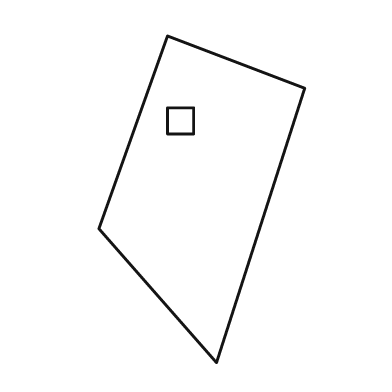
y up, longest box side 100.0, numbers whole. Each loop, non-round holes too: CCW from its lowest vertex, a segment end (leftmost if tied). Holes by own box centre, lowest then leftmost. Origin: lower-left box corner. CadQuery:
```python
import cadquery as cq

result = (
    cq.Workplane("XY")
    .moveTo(36.0, 0.0)
    .lineTo(63.0, 84.0)
    .lineTo(21.0, 100.0)
    .lineTo(0.0, 41.0)
    .close()
    .moveTo(21.0, 70.0)
    .lineTo(29.0, 70.0)
    .lineTo(29.0, 78.0)
    .lineTo(21.0, 78.0)
    .close()
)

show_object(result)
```